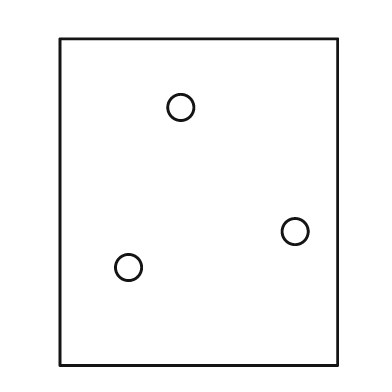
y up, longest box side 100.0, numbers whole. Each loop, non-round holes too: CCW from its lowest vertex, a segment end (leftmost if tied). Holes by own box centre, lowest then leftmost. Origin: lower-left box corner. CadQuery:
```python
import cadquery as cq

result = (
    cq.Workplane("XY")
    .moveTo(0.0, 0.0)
    .lineTo(85.0, 0.0)
    .lineTo(85.0, 100.0)
    .lineTo(0.0, 100.0)
    .close()
    .moveTo(21.0, 30.0)
    .circle(4.0)
    .moveTo(72.0, 41.0)
    .circle(4.0)
    .moveTo(37.0, 79.0)
    .circle(4.0)
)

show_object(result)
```